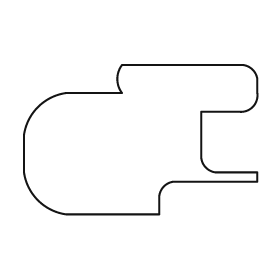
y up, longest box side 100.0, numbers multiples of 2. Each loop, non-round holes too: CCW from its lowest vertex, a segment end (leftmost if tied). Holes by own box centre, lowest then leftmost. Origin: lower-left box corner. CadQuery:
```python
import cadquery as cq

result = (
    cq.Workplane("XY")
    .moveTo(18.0, 0.0)
    .lineTo(58.0, 0.0)
    .lineTo(58.0, 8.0)
    .threePointArc((60.0, 12.0), (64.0, 14.0))
    .lineTo(100.0, 14.0)
    .lineTo(100.0, 18.0)
    .lineTo(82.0, 18.0)
    .threePointArc((78.0, 20.0), (76.0, 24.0))
    .lineTo(76.0, 44.0)
    .lineTo(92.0, 44.0)
    .threePointArc((98.0, 46.0), (100.0, 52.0))
    .lineTo(100.0, 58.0)
    .threePointArc((98.0, 62.0), (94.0, 64.0))
    .lineTo(42.0, 64.0)
    .threePointArc((40.0, 58.0), (42.0, 52.0))
    .lineTo(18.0, 52.0)
    .threePointArc((6.0, 46.0), (0.0, 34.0))
    .lineTo(0.0, 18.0)
    .threePointArc((6.0, 6.0), (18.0, 0.0))
    .close()
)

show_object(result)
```